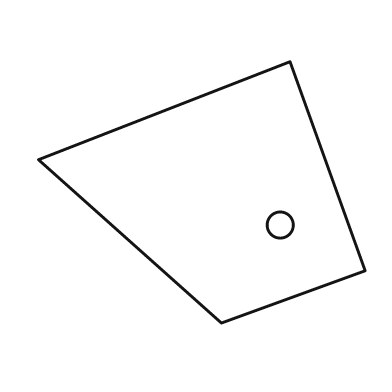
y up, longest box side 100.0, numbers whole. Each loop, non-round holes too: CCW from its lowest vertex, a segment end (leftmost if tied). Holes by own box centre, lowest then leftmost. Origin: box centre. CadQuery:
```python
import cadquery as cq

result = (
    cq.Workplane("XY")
    .moveTo(6.0, -40.0)
    .lineTo(50.0, -24.0)
    .lineTo(27.0, 40.0)
    .lineTo(-50.0, 10.0)
    .close()
    .moveTo(24.0, -10.0)
    .circle(4.0)
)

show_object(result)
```